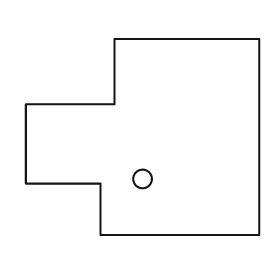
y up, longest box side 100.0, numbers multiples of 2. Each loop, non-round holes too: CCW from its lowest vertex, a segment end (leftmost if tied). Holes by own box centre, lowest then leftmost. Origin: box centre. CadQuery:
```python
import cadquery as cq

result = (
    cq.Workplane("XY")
    .moveTo(-18.0, -42.0)
    .lineTo(50.0, -42.0)
    .lineTo(50.0, 42.0)
    .lineTo(-12.0, 42.0)
    .lineTo(-12.0, 14.0)
    .lineTo(-50.0, 14.0)
    .lineTo(-50.0, -20.0)
    .lineTo(-18.0, -20.0)
    .close()
    .moveTo(0.0, -18.0)
    .circle(4.0)
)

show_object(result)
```